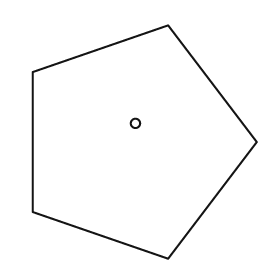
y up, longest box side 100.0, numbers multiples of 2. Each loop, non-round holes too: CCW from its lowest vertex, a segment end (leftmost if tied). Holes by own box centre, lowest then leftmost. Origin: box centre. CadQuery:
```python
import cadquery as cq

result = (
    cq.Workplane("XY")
    .moveTo(10.0, -50.0)
    .lineTo(48.0, 0.0)
    .lineTo(10.0, 50.0)
    .lineTo(-48.0, 30.0)
    .lineTo(-48.0, -30.0)
    .close()
    .moveTo(-4.0, 8.0)
    .circle(2.0)
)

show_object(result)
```